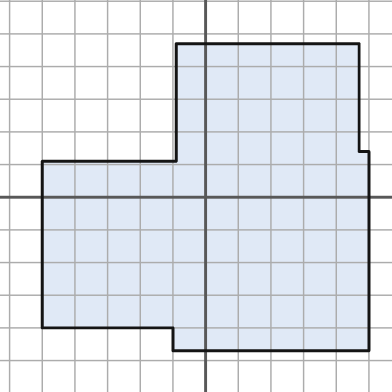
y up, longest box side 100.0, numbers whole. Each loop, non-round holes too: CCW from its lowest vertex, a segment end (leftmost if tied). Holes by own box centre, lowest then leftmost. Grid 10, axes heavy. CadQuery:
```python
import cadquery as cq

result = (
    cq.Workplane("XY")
    .moveTo(-10.0, -47.0)
    .lineTo(50.0, -47.0)
    .lineTo(50.0, 14.0)
    .lineTo(47.0, 14.0)
    .lineTo(47.0, 47.0)
    .lineTo(-9.0, 47.0)
    .lineTo(-9.0, 11.0)
    .lineTo(-50.0, 11.0)
    .lineTo(-50.0, -40.0)
    .lineTo(-10.0, -40.0)
    .close()
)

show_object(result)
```